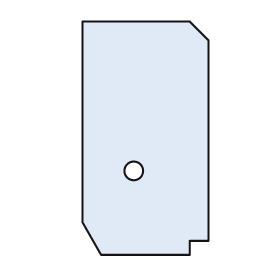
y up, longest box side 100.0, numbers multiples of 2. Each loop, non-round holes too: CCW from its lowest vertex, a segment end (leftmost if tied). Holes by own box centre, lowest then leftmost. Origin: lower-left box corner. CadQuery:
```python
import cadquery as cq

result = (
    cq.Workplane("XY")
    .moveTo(8.0, 0.0)
    .lineTo(46.0, 0.0)
    .lineTo(46.0, 6.0)
    .lineTo(54.0, 6.0)
    .lineTo(54.0, 92.0)
    .lineTo(46.0, 100.0)
    .lineTo(0.0, 100.0)
    .lineTo(0.0, 14.0)
    .close()
    .moveTo(22.0, 36.0)
    .circle(4.0)
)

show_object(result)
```